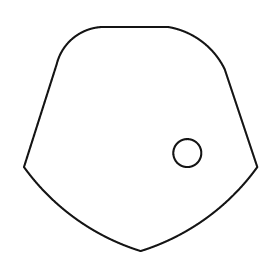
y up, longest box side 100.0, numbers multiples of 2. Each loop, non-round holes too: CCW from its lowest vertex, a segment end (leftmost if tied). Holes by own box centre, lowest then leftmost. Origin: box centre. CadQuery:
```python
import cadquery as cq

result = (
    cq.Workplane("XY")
    .moveTo(0.0, -48.0)
    .threePointArc((28.0, -34.0), (50.0, -12.0))
    .lineTo(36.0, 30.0)
    .threePointArc((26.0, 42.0), (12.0, 48.0))
    .lineTo(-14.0, 48.0)
    .threePointArc((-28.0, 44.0), (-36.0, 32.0))
    .lineTo(-50.0, -12.0)
    .threePointArc((-28.0, -34.0), (0.0, -48.0))
    .close()
    .moveTo(20.0, -6.0)
    .circle(6.0)
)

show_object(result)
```